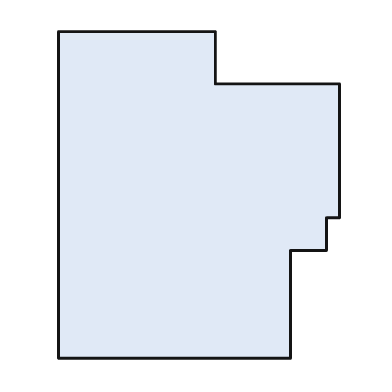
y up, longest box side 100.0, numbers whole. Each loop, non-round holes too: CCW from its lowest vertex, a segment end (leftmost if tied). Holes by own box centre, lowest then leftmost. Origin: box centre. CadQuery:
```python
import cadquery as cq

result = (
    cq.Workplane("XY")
    .moveTo(-43.0, -50.0)
    .lineTo(28.0, -50.0)
    .lineTo(28.0, -17.0)
    .lineTo(39.0, -17.0)
    .lineTo(39.0, -7.0)
    .lineTo(43.0, -7.0)
    .lineTo(43.0, 34.0)
    .lineTo(5.0, 34.0)
    .lineTo(5.0, 50.0)
    .lineTo(-43.0, 50.0)
    .close()
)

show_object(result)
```